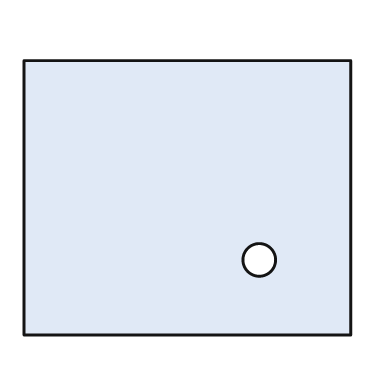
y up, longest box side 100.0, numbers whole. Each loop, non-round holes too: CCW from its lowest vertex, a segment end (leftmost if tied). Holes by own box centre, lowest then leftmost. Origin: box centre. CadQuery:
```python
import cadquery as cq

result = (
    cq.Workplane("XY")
    .moveTo(-50.0, -42.0)
    .lineTo(50.0, -42.0)
    .lineTo(50.0, 42.0)
    .lineTo(-50.0, 42.0)
    .close()
    .moveTo(22.0, -19.0)
    .circle(5.0)
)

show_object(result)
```